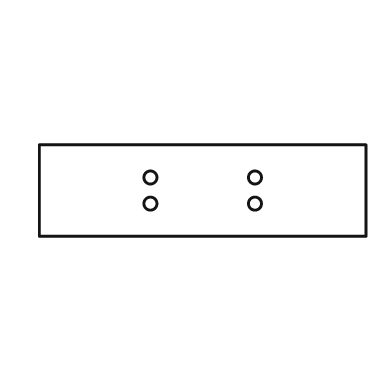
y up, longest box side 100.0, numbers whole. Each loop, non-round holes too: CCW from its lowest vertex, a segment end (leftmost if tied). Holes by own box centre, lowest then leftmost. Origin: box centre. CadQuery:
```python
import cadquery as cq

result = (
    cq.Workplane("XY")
    .moveTo(-50.0, -14.0)
    .lineTo(50.0, -14.0)
    .lineTo(50.0, 14.0)
    .lineTo(-50.0, 14.0)
    .close()
    .moveTo(-16.0, -4.0)
    .circle(2.0)
    .moveTo(16.0, -4.0)
    .circle(2.0)
    .moveTo(-16.0, 4.0)
    .circle(2.0)
    .moveTo(16.0, 4.0)
    .circle(2.0)
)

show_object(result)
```